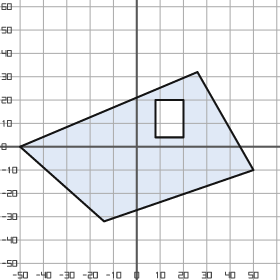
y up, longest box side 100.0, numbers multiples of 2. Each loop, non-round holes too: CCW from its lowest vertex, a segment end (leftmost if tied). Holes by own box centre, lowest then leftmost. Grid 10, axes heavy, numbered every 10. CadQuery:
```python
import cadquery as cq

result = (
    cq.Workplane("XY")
    .moveTo(-14.0, -32.0)
    .lineTo(50.0, -10.0)
    .lineTo(26.0, 32.0)
    .lineTo(-50.0, 0.0)
    .close()
    .moveTo(8.0, 4.0)
    .lineTo(20.0, 4.0)
    .lineTo(20.0, 20.0)
    .lineTo(8.0, 20.0)
    .close()
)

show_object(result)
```